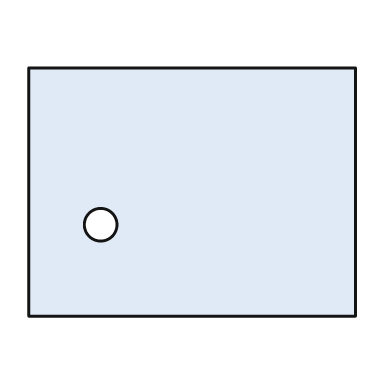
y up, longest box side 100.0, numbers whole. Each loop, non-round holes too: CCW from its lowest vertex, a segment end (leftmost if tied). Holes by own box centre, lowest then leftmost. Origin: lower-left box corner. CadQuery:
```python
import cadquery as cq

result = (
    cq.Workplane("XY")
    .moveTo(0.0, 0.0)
    .lineTo(100.0, 0.0)
    .lineTo(100.0, 76.0)
    .lineTo(0.0, 76.0)
    .close()
    .moveTo(22.0, 28.0)
    .circle(5.0)
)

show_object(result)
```